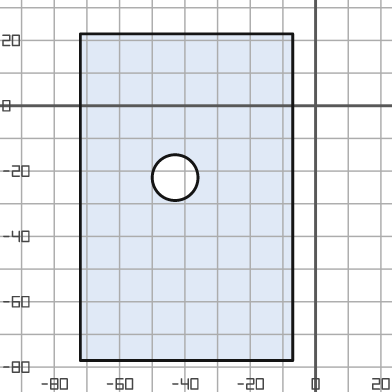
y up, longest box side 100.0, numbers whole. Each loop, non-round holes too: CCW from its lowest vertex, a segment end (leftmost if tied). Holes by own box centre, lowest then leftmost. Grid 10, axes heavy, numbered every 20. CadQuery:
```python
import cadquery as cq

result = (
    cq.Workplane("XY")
    .moveTo(-72.0, -78.0)
    .lineTo(-7.0, -78.0)
    .lineTo(-7.0, 22.0)
    .lineTo(-72.0, 22.0)
    .close()
    .moveTo(-43.0, -22.0)
    .circle(7.0)
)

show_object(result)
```